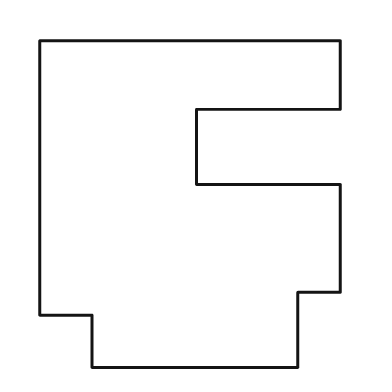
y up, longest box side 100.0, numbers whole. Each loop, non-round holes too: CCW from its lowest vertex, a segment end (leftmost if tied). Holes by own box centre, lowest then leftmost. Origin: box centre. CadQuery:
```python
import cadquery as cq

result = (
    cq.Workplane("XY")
    .moveTo(-30.0, -50.0)
    .lineTo(33.0, -50.0)
    .lineTo(33.0, -27.0)
    .lineTo(46.0, -27.0)
    .lineTo(46.0, 6.0)
    .lineTo(2.0, 6.0)
    .lineTo(2.0, 29.0)
    .lineTo(46.0, 29.0)
    .lineTo(46.0, 50.0)
    .lineTo(-46.0, 50.0)
    .lineTo(-46.0, -34.0)
    .lineTo(-30.0, -34.0)
    .close()
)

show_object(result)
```